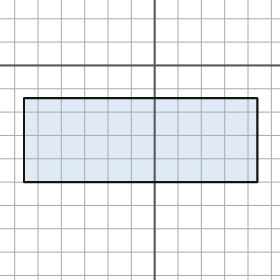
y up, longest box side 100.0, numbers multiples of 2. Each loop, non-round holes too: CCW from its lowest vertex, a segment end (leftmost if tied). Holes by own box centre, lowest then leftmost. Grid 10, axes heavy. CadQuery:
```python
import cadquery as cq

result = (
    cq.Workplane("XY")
    .moveTo(-56.0, -50.0)
    .lineTo(44.0, -50.0)
    .lineTo(44.0, -14.0)
    .lineTo(-56.0, -14.0)
    .close()
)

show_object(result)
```